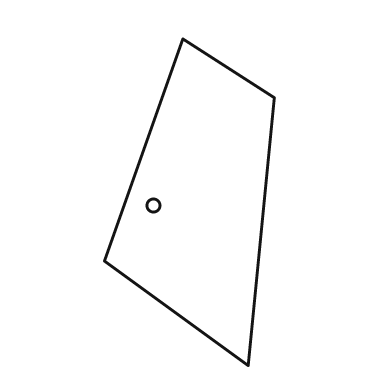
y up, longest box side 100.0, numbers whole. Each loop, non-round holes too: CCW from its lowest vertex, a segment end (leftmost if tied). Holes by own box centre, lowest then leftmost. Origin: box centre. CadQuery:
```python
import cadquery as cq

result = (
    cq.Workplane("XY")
    .moveTo(18.0, -50.0)
    .lineTo(26.0, 32.0)
    .lineTo(-2.0, 50.0)
    .lineTo(-26.0, -18.0)
    .close()
    .moveTo(-11.0, -1.0)
    .circle(2.0)
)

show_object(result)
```